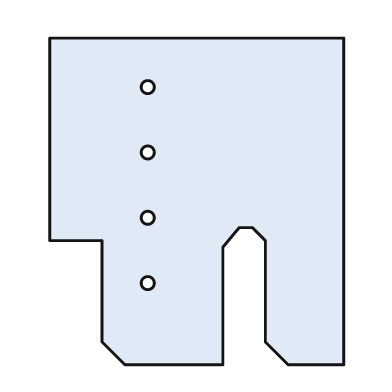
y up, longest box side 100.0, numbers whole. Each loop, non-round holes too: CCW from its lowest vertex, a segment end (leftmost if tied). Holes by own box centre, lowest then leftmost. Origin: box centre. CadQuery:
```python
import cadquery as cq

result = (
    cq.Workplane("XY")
    .moveTo(-22.0, -50.0)
    .lineTo(8.0, -50.0)
    .lineTo(8.0, -14.0)
    .lineTo(13.0, -8.0)
    .lineTo(17.0, -8.0)
    .lineTo(21.0, -12.0)
    .lineTo(21.0, -43.0)
    .lineTo(28.0, -50.0)
    .lineTo(45.0, -50.0)
    .lineTo(45.0, 50.0)
    .lineTo(-45.0, 50.0)
    .lineTo(-45.0, -12.0)
    .lineTo(-29.0, -12.0)
    .lineTo(-29.0, -43.0)
    .close()
    .moveTo(-15.0, -25.0)
    .circle(2.0)
    .moveTo(-15.0, -5.0)
    .circle(2.0)
    .moveTo(-15.0, 15.0)
    .circle(2.0)
    .moveTo(-15.0, 35.0)
    .circle(2.0)
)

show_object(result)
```